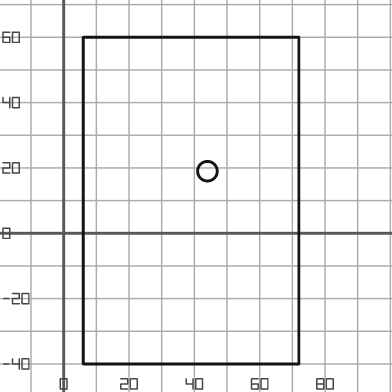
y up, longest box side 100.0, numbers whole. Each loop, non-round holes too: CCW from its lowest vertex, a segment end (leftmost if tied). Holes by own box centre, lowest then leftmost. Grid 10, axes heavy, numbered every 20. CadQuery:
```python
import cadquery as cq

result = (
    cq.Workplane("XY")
    .moveTo(6.0, -40.0)
    .lineTo(72.0, -40.0)
    .lineTo(72.0, 60.0)
    .lineTo(6.0, 60.0)
    .close()
    .moveTo(44.0, 19.0)
    .circle(3.0)
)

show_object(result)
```